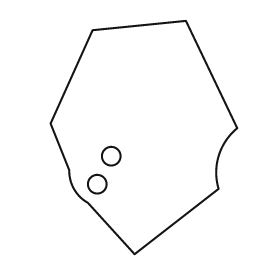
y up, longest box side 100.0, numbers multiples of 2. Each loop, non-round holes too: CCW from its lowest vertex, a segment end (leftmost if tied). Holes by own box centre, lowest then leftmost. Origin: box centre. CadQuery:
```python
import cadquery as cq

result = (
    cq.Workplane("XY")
    .moveTo(-4.0, -50.0)
    .lineTo(32.0, -22.0)
    .threePointArc((32.0, -8.0), (40.0, 4.0))
    .lineTo(18.0, 50.0)
    .lineTo(-22.0, 46.0)
    .lineTo(-40.0, 6.0)
    .lineTo(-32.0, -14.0)
    .threePointArc((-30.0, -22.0), (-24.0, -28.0))
    .close()
    .moveTo(-20.0, -20.0)
    .circle(4.0)
    .moveTo(-14.0, -8.0)
    .circle(4.0)
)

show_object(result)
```